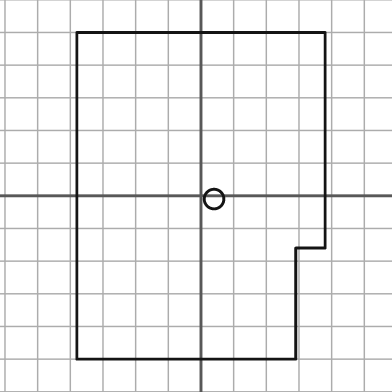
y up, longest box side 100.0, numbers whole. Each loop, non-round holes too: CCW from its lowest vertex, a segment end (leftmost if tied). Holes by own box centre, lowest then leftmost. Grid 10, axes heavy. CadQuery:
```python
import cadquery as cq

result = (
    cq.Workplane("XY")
    .moveTo(-38.0, -50.0)
    .lineTo(29.0, -50.0)
    .lineTo(29.0, -16.0)
    .lineTo(38.0, -16.0)
    .lineTo(38.0, 50.0)
    .lineTo(-38.0, 50.0)
    .close()
    .moveTo(4.0, -1.0)
    .circle(3.0)
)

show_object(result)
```